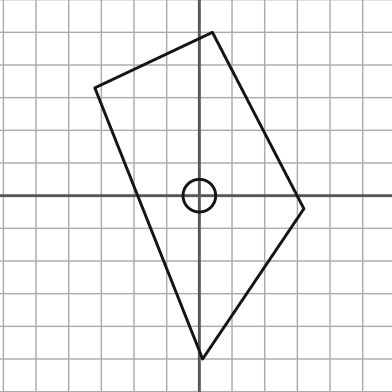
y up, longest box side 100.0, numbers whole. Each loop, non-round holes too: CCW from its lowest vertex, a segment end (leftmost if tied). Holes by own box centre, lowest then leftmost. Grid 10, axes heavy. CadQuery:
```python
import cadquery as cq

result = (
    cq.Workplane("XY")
    .moveTo(1.0, -50.0)
    .lineTo(32.0, -4.0)
    .lineTo(4.0, 50.0)
    .lineTo(-32.0, 33.0)
    .close()
    .moveTo(0.0, 0.0)
    .circle(5.0)
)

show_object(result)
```